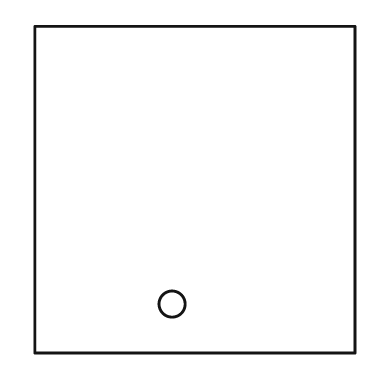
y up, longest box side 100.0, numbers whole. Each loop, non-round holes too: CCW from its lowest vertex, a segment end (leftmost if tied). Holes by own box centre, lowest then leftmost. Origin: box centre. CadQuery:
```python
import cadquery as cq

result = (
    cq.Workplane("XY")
    .moveTo(-49.0, -50.0)
    .lineTo(49.0, -50.0)
    .lineTo(49.0, 50.0)
    .lineTo(-49.0, 50.0)
    .close()
    .moveTo(-7.0, -35.0)
    .circle(4.0)
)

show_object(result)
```